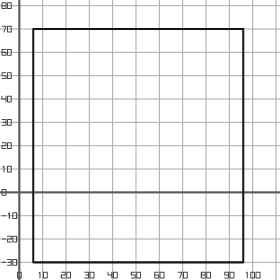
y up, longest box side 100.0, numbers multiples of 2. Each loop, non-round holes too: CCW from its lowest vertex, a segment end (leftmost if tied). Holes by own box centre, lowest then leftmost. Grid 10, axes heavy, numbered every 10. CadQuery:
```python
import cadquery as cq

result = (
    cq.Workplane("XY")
    .moveTo(6.0, -30.0)
    .lineTo(96.0, -30.0)
    .lineTo(96.0, 70.0)
    .lineTo(6.0, 70.0)
    .close()
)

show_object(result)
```